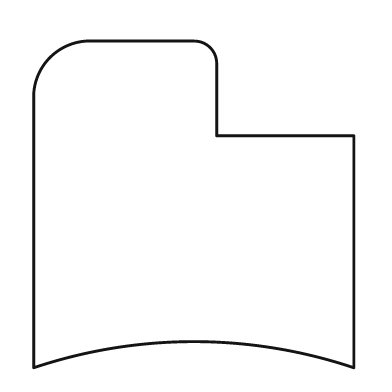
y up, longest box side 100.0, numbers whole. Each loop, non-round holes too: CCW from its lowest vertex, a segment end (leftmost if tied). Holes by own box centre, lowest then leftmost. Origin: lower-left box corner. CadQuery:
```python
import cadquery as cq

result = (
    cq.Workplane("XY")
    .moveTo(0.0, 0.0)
    .threePointArc((49.0, 8.0), (98.0, 0.0))
    .lineTo(98.0, 71.0)
    .lineTo(56.0, 71.0)
    .lineTo(56.0, 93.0)
    .threePointArc((54.0, 98.0), (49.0, 100.0))
    .lineTo(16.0, 100.0)
    .threePointArc((5.0, 95.0), (0.0, 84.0))
    .close()
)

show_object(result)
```